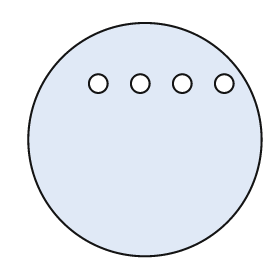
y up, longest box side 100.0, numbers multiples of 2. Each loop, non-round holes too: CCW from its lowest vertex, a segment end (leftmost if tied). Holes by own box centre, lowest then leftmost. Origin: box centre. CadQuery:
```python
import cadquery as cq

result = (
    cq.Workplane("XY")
    .moveTo(0.0, 0.0)
    .circle(50.0)
    .moveTo(-20.0, 24.0)
    .circle(4.0)
    .moveTo(-2.0, 24.0)
    .circle(4.0)
    .moveTo(16.0, 24.0)
    .circle(4.0)
    .moveTo(34.0, 24.0)
    .circle(4.0)
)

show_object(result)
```